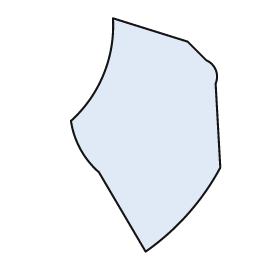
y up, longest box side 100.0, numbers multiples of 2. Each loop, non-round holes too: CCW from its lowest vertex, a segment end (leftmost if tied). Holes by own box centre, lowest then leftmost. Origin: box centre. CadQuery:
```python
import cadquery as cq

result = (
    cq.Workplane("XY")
    .moveTo(0.0, -50.0)
    .threePointArc((18.0, -34.0), (32.0, -14.0))
    .lineTo(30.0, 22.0)
    .threePointArc((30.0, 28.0), (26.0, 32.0))
    .lineTo(18.0, 40.0)
    .lineTo(-14.0, 50.0)
    .threePointArc((-18.0, 26.0), (-32.0, 6.0))
    .threePointArc((-28.0, -6.0), (-20.0, -16.0))
    .close()
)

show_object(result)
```